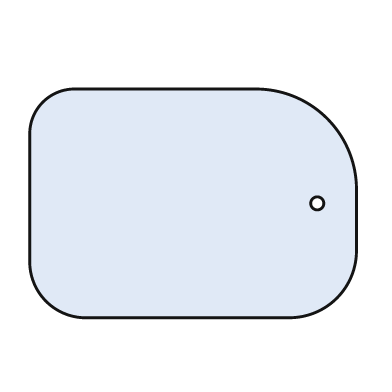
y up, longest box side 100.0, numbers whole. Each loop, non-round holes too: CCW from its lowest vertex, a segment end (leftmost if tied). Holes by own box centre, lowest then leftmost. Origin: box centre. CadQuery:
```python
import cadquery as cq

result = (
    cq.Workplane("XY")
    .moveTo(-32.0, -35.0)
    .lineTo(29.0, -35.0)
    .threePointArc((44.0, -29.0), (50.0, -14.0))
    .lineTo(50.0, 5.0)
    .threePointArc((41.0, 26.0), (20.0, 35.0))
    .lineTo(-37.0, 35.0)
    .threePointArc((-46.0, 31.0), (-50.0, 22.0))
    .lineTo(-50.0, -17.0)
    .threePointArc((-45.0, -30.0), (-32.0, -35.0))
    .close()
    .moveTo(38.0, 0.0)
    .circle(2.0)
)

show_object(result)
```